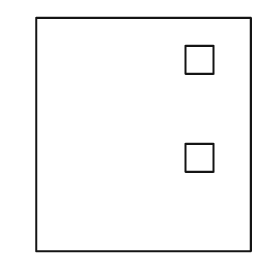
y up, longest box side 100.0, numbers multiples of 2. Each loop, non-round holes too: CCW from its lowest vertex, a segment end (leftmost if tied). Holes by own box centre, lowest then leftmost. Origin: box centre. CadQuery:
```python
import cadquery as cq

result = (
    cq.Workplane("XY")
    .moveTo(-46.0, -50.0)
    .lineTo(46.0, -50.0)
    .lineTo(46.0, 50.0)
    .lineTo(-46.0, 50.0)
    .close()
    .moveTo(18.0, -16.0)
    .lineTo(30.0, -16.0)
    .lineTo(30.0, -4.0)
    .lineTo(18.0, -4.0)
    .close()
    .moveTo(18.0, 26.0)
    .lineTo(30.0, 26.0)
    .lineTo(30.0, 38.0)
    .lineTo(18.0, 38.0)
    .close()
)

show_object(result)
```